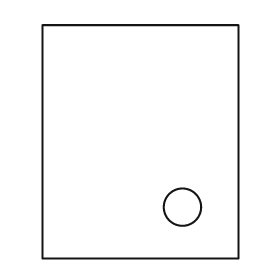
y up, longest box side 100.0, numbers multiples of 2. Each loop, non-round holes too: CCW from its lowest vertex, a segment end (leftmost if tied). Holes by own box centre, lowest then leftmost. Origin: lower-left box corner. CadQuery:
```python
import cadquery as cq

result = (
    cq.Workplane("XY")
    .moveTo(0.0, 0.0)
    .lineTo(84.0, 0.0)
    .lineTo(84.0, 100.0)
    .lineTo(0.0, 100.0)
    .close()
    .moveTo(60.0, 22.0)
    .circle(8.0)
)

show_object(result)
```